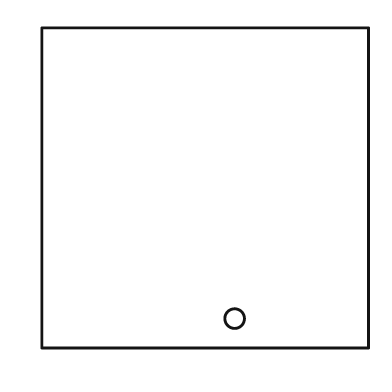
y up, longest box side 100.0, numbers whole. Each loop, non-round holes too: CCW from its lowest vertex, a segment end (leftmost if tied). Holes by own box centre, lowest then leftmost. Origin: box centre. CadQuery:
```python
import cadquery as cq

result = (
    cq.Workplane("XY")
    .moveTo(-50.0, -49.0)
    .lineTo(50.0, -49.0)
    .lineTo(50.0, 49.0)
    .lineTo(-50.0, 49.0)
    .close()
    .moveTo(9.0, -40.0)
    .circle(3.0)
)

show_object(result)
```